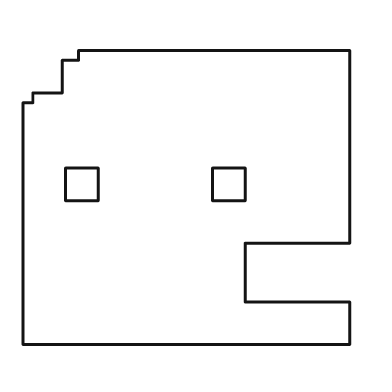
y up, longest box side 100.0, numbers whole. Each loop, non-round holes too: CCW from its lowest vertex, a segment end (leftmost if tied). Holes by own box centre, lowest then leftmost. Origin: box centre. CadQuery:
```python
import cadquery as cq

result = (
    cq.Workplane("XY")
    .moveTo(-50.0, -45.0)
    .lineTo(50.0, -45.0)
    .lineTo(50.0, -32.0)
    .lineTo(18.0, -32.0)
    .lineTo(18.0, -14.0)
    .lineTo(50.0, -14.0)
    .lineTo(50.0, 45.0)
    .lineTo(-33.0, 45.0)
    .lineTo(-33.0, 42.0)
    .lineTo(-38.0, 42.0)
    .lineTo(-38.0, 32.0)
    .lineTo(-47.0, 32.0)
    .lineTo(-47.0, 29.0)
    .lineTo(-50.0, 29.0)
    .close()
    .moveTo(-37.0, -1.0)
    .lineTo(-27.0, -1.0)
    .lineTo(-27.0, 9.0)
    .lineTo(-37.0, 9.0)
    .close()
    .moveTo(8.0, -1.0)
    .lineTo(18.0, -1.0)
    .lineTo(18.0, 9.0)
    .lineTo(8.0, 9.0)
    .close()
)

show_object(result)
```